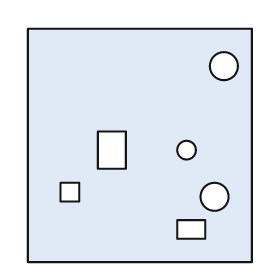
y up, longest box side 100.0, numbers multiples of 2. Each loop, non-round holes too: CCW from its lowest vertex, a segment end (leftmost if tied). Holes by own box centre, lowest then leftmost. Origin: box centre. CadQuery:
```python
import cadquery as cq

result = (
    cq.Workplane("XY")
    .moveTo(-48.0, -50.0)
    .lineTo(48.0, -50.0)
    .lineTo(48.0, 50.0)
    .lineTo(-48.0, 50.0)
    .close()
    .moveTo(16.0, -40.0)
    .lineTo(28.0, -40.0)
    .lineTo(28.0, -32.0)
    .lineTo(16.0, -32.0)
    .close()
    .moveTo(32.0, -22.0)
    .circle(6.0)
    .moveTo(-34.0, -24.0)
    .lineTo(-26.0, -24.0)
    .lineTo(-26.0, -16.0)
    .lineTo(-34.0, -16.0)
    .close()
    .moveTo(-18.0, -10.0)
    .lineTo(-6.0, -10.0)
    .lineTo(-6.0, 6.0)
    .lineTo(-18.0, 6.0)
    .close()
    .moveTo(20.0, -2.0)
    .circle(4.0)
    .moveTo(36.0, 34.0)
    .circle(6.0)
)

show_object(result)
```